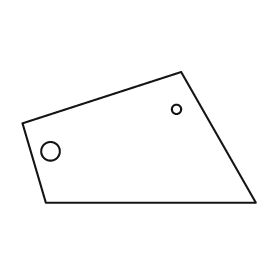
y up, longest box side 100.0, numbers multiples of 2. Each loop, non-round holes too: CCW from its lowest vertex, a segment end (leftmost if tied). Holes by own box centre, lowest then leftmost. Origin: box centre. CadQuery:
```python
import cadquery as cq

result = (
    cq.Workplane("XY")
    .moveTo(-40.0, -28.0)
    .lineTo(50.0, -28.0)
    .lineTo(18.0, 28.0)
    .lineTo(-50.0, 6.0)
    .close()
    .moveTo(-38.0, -6.0)
    .circle(4.0)
    .moveTo(16.0, 12.0)
    .circle(2.0)
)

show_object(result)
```